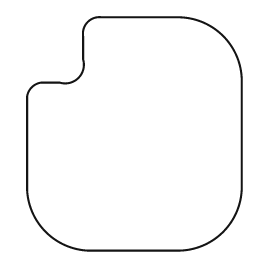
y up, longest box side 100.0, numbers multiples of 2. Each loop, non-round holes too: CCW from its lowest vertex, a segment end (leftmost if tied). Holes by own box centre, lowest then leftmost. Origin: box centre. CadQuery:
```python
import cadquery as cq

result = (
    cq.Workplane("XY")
    .moveTo(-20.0, -50.0)
    .lineTo(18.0, -50.0)
    .threePointArc((38.0, -42.0), (46.0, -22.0))
    .lineTo(46.0, 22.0)
    .threePointArc((38.0, 42.0), (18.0, 50.0))
    .lineTo(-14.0, 50.0)
    .threePointArc((-20.0, 48.0), (-22.0, 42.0))
    .lineTo(-22.0, 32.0)
    .threePointArc((-24.0, 24.0), (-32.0, 22.0))
    .lineTo(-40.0, 22.0)
    .threePointArc((-44.0, 20.0), (-46.0, 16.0))
    .lineTo(-46.0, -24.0)
    .threePointArc((-38.0, -42.0), (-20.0, -50.0))
    .close()
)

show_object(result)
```